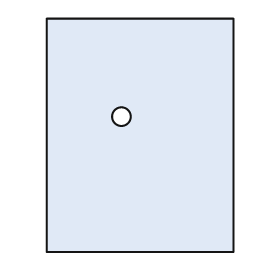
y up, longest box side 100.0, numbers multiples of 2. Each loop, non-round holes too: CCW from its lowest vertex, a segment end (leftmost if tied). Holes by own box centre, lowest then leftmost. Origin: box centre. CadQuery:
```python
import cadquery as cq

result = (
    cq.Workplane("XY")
    .moveTo(-40.0, -50.0)
    .lineTo(40.0, -50.0)
    .lineTo(40.0, 50.0)
    .lineTo(-40.0, 50.0)
    .close()
    .moveTo(-8.0, 8.0)
    .circle(4.0)
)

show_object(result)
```